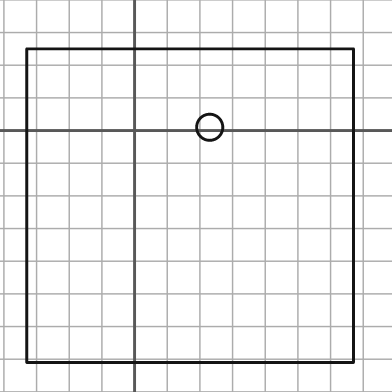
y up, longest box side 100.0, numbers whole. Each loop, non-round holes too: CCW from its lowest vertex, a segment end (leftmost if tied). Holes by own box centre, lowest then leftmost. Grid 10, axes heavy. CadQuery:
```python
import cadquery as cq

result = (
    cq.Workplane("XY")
    .moveTo(-33.0, -71.0)
    .lineTo(67.0, -71.0)
    .lineTo(67.0, 25.0)
    .lineTo(-33.0, 25.0)
    .close()
    .moveTo(23.0, 1.0)
    .circle(4.0)
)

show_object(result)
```